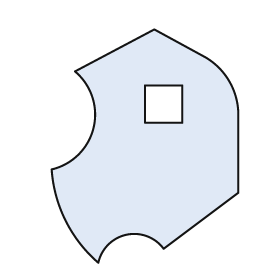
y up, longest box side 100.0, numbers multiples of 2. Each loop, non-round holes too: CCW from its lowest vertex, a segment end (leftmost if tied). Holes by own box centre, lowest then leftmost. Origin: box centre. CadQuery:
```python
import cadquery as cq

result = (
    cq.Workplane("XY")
    .moveTo(-20.0, -50.0)
    .threePointArc((-8.0, -38.0), (8.0, -44.0))
    .lineTo(40.0, -20.0)
    .lineTo(40.0, 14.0)
    .threePointArc((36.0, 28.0), (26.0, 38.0))
    .lineTo(4.0, 50.0)
    .lineTo(-30.0, 32.0)
    .threePointArc((-22.0, 8.0), (-40.0, -10.0))
    .threePointArc((-34.0, -32.0), (-20.0, -50.0))
    .close()
    .moveTo(0.0, 10.0)
    .lineTo(16.0, 10.0)
    .lineTo(16.0, 26.0)
    .lineTo(0.0, 26.0)
    .close()
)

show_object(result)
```